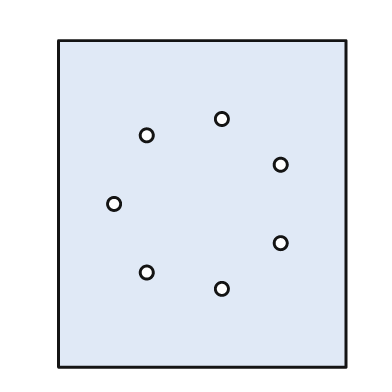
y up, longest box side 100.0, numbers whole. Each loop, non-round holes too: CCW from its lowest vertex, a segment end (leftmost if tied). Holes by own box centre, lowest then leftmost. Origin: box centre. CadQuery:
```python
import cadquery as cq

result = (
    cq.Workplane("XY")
    .moveTo(-44.0, -50.0)
    .lineTo(44.0, -50.0)
    .lineTo(44.0, 50.0)
    .lineTo(-44.0, 50.0)
    .close()
    .moveTo(6.0, -26.0)
    .circle(2.0)
    .moveTo(-17.0, -21.0)
    .circle(2.0)
    .moveTo(24.0, -12.0)
    .circle(2.0)
    .moveTo(-27.0, 0.0)
    .circle(2.0)
    .moveTo(24.0, 12.0)
    .circle(2.0)
    .moveTo(-17.0, 21.0)
    .circle(2.0)
    .moveTo(6.0, 26.0)
    .circle(2.0)
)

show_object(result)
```